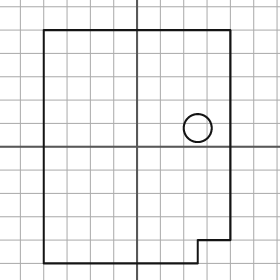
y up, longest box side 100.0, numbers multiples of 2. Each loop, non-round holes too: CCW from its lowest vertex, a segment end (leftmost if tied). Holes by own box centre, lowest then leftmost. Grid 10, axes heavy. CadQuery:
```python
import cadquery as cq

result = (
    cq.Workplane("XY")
    .moveTo(-40.0, -50.0)
    .lineTo(26.0, -50.0)
    .lineTo(26.0, -40.0)
    .lineTo(40.0, -40.0)
    .lineTo(40.0, 50.0)
    .lineTo(-40.0, 50.0)
    .close()
    .moveTo(26.0, 8.0)
    .circle(6.0)
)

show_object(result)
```